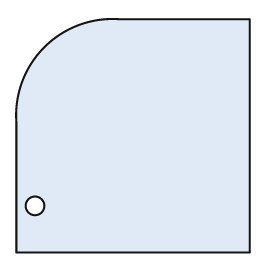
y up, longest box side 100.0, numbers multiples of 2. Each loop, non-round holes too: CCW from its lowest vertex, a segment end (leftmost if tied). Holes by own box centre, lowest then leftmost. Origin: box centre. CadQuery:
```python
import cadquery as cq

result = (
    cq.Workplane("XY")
    .moveTo(-50.0, -50.0)
    .lineTo(50.0, -50.0)
    .lineTo(50.0, 50.0)
    .lineTo(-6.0, 50.0)
    .threePointArc((-38.0, 38.0), (-50.0, 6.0))
    .close()
    .moveTo(-42.0, -30.0)
    .circle(4.0)
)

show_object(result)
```